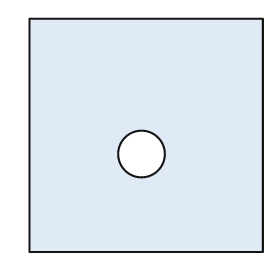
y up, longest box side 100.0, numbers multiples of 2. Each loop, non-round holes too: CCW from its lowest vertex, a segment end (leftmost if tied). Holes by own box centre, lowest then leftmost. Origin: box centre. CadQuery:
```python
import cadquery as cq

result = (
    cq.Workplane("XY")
    .moveTo(-50.0, -50.0)
    .lineTo(50.0, -50.0)
    .lineTo(50.0, 50.0)
    .lineTo(-50.0, 50.0)
    .close()
    .moveTo(-2.0, -8.0)
    .circle(10.0)
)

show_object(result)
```